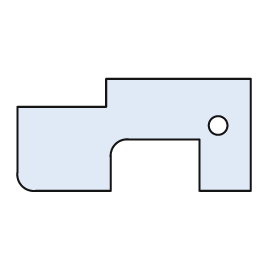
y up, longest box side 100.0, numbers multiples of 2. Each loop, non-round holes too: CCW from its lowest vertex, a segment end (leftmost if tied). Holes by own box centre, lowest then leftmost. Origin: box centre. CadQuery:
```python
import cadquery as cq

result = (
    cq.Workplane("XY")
    .moveTo(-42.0, -24.0)
    .lineTo(-10.0, -24.0)
    .lineTo(-10.0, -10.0)
    .threePointArc((-8.0, -4.0), (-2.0, -2.0))
    .lineTo(28.0, -2.0)
    .lineTo(28.0, -24.0)
    .lineTo(50.0, -24.0)
    .lineTo(50.0, 24.0)
    .lineTo(-12.0, 24.0)
    .lineTo(-12.0, 12.0)
    .lineTo(-50.0, 12.0)
    .lineTo(-50.0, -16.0)
    .threePointArc((-48.0, -22.0), (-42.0, -24.0))
    .close()
    .moveTo(36.0, 4.0)
    .circle(4.0)
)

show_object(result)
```